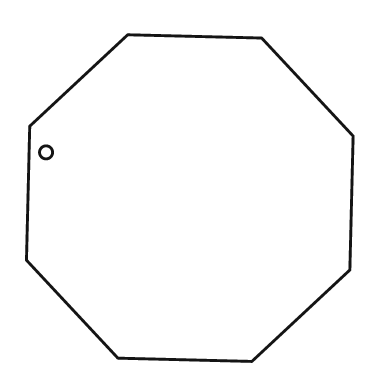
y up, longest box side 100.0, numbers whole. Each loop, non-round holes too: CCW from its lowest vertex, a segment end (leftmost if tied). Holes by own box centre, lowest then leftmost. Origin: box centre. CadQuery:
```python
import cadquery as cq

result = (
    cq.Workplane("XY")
    .moveTo(19.0, -50.0)
    .lineTo(49.0, -22.0)
    .lineTo(50.0, 19.0)
    .lineTo(22.0, 49.0)
    .lineTo(-19.0, 50.0)
    .lineTo(-49.0, 22.0)
    .lineTo(-50.0, -19.0)
    .lineTo(-22.0, -49.0)
    .close()
    .moveTo(-44.0, 14.0)
    .circle(2.0)
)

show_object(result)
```